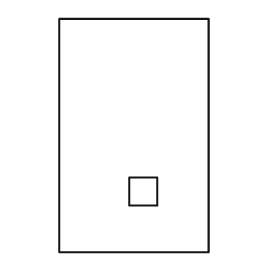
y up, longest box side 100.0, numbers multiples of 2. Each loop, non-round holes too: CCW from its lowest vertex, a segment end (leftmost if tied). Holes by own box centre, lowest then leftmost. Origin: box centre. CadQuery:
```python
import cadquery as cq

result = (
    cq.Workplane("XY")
    .moveTo(-32.0, -50.0)
    .lineTo(32.0, -50.0)
    .lineTo(32.0, 50.0)
    .lineTo(-32.0, 50.0)
    .close()
    .moveTo(-2.0, -30.0)
    .lineTo(10.0, -30.0)
    .lineTo(10.0, -18.0)
    .lineTo(-2.0, -18.0)
    .close()
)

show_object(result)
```